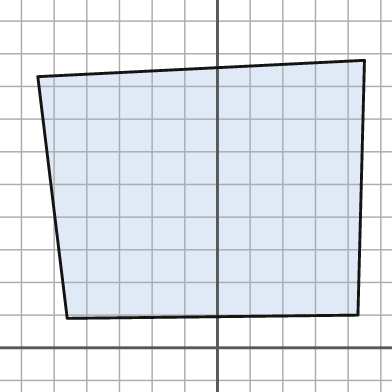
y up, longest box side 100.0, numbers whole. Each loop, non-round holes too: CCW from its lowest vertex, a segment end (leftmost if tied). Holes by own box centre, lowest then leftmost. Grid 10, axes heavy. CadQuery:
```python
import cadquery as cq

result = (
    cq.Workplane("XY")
    .moveTo(-46.0, 9.0)
    .lineTo(43.0, 10.0)
    .lineTo(45.0, 88.0)
    .lineTo(-55.0, 83.0)
    .close()
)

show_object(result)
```